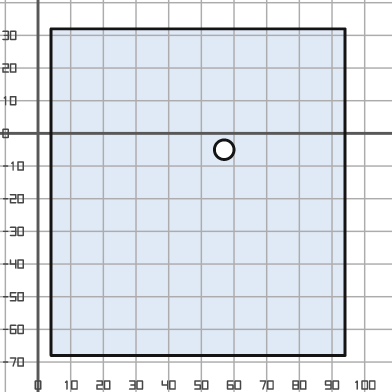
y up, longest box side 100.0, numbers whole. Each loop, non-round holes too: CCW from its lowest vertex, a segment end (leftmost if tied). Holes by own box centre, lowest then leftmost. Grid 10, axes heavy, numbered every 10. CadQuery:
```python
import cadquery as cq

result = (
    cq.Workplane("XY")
    .moveTo(4.0, -68.0)
    .lineTo(94.0, -68.0)
    .lineTo(94.0, 32.0)
    .lineTo(4.0, 32.0)
    .close()
    .moveTo(57.0, -5.0)
    .circle(3.0)
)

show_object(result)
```